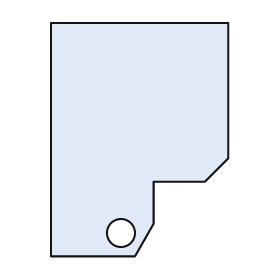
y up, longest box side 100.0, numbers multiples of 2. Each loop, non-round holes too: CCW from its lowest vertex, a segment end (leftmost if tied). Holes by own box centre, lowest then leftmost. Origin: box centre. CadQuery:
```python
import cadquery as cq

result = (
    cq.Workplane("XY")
    .moveTo(-38.0, -50.0)
    .lineTo(-2.0, -50.0)
    .lineTo(6.0, -36.0)
    .lineTo(6.0, -18.0)
    .lineTo(28.0, -18.0)
    .lineTo(38.0, -8.0)
    .lineTo(38.0, 50.0)
    .lineTo(-38.0, 50.0)
    .close()
    .moveTo(-8.0, -40.0)
    .circle(6.0)
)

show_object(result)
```